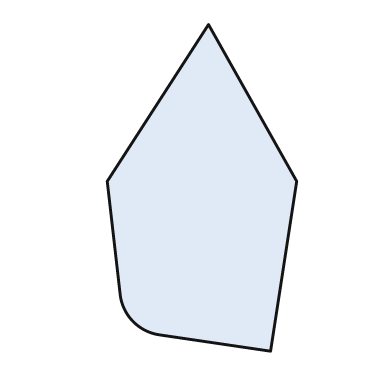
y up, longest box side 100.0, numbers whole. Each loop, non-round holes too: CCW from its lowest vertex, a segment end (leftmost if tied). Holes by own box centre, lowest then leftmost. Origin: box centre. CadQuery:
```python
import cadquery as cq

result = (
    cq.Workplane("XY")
    .moveTo(21.0, -50.0)
    .lineTo(29.0, 2.0)
    .lineTo(2.0, 50.0)
    .lineTo(-29.0, 2.0)
    .lineTo(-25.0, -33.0)
    .threePointArc((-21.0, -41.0), (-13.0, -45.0))
    .close()
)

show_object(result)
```